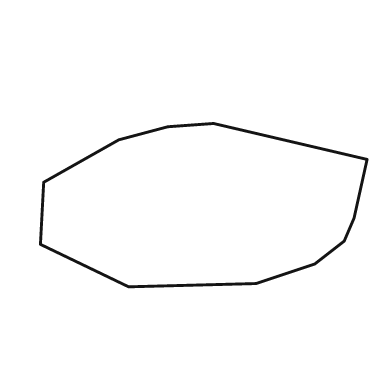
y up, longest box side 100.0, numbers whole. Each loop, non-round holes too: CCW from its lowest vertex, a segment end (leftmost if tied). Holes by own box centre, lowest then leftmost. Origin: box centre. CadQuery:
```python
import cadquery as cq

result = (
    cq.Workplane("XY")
    .moveTo(-23.0, -25.0)
    .lineTo(16.0, -24.0)
    .lineTo(34.0, -18.0)
    .lineTo(43.0, -11.0)
    .lineTo(46.0, -4.0)
    .lineTo(50.0, 14.0)
    .lineTo(3.0, 25.0)
    .lineTo(-11.0, 24.0)
    .lineTo(-26.0, 20.0)
    .lineTo(-49.0, 7.0)
    .lineTo(-50.0, -12.0)
    .close()
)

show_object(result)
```